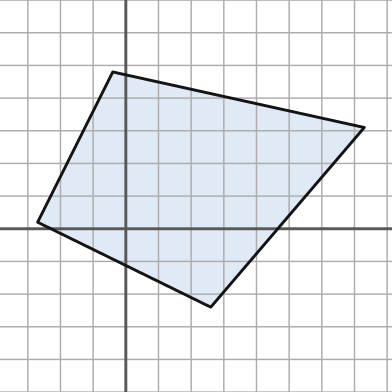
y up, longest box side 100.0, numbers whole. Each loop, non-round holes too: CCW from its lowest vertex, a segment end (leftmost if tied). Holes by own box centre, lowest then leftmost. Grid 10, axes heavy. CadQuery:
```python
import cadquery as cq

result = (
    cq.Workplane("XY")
    .moveTo(26.0, -24.0)
    .lineTo(73.0, 31.0)
    .lineTo(-4.0, 48.0)
    .lineTo(-27.0, 2.0)
    .close()
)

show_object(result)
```